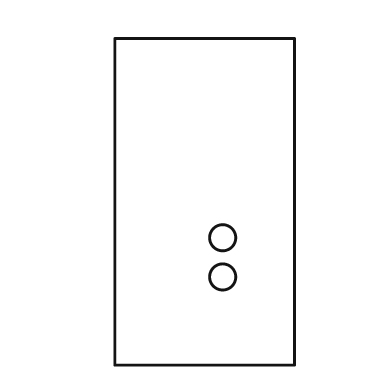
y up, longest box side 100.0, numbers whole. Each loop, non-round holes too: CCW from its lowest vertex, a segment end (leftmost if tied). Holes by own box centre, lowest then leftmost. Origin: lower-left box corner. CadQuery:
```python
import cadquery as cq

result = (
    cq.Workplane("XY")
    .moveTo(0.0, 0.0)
    .lineTo(55.0, 0.0)
    .lineTo(55.0, 100.0)
    .lineTo(0.0, 100.0)
    .close()
    .moveTo(33.0, 27.0)
    .circle(4.0)
    .moveTo(33.0, 39.0)
    .circle(4.0)
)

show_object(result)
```